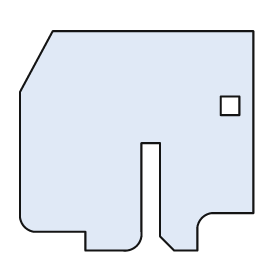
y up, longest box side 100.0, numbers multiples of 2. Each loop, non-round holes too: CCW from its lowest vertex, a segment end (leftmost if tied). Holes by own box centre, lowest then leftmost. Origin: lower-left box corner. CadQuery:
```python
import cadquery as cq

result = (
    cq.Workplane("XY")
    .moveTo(28.0, 0.0)
    .lineTo(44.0, 0.0)
    .threePointArc((50.0, 2.0), (52.0, 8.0))
    .lineTo(52.0, 46.0)
    .lineTo(60.0, 46.0)
    .lineTo(60.0, 6.0)
    .lineTo(66.0, 0.0)
    .lineTo(76.0, 0.0)
    .lineTo(76.0, 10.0)
    .threePointArc((78.0, 14.0), (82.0, 16.0))
    .lineTo(100.0, 16.0)
    .lineTo(100.0, 94.0)
    .lineTo(14.0, 94.0)
    .lineTo(0.0, 68.0)
    .lineTo(0.0, 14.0)
    .threePointArc((2.0, 10.0), (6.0, 8.0))
    .lineTo(28.0, 8.0)
    .close()
    .moveTo(86.0, 58.0)
    .lineTo(94.0, 58.0)
    .lineTo(94.0, 66.0)
    .lineTo(86.0, 66.0)
    .close()
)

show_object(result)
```